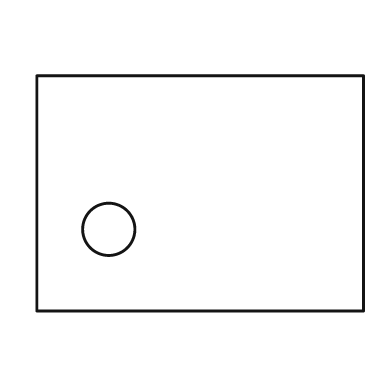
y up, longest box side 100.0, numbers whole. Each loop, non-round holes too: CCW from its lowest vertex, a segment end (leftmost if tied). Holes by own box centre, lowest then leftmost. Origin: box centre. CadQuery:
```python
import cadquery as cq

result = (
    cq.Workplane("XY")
    .moveTo(-50.0, -36.0)
    .lineTo(50.0, -36.0)
    .lineTo(50.0, 36.0)
    .lineTo(-50.0, 36.0)
    .close()
    .moveTo(-28.0, -11.0)
    .circle(8.0)
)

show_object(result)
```